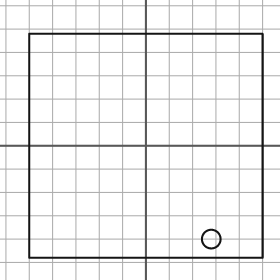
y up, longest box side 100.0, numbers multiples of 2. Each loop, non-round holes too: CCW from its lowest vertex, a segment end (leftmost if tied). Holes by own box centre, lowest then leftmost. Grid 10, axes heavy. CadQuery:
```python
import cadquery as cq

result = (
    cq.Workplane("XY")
    .moveTo(-50.0, -48.0)
    .lineTo(50.0, -48.0)
    .lineTo(50.0, 48.0)
    .lineTo(-50.0, 48.0)
    .close()
    .moveTo(28.0, -40.0)
    .circle(4.0)
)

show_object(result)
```